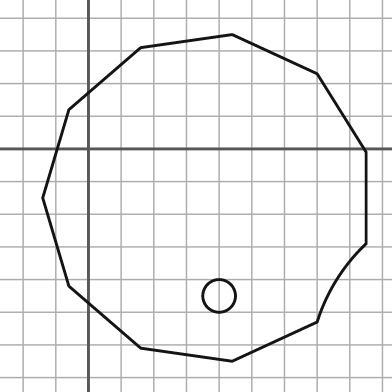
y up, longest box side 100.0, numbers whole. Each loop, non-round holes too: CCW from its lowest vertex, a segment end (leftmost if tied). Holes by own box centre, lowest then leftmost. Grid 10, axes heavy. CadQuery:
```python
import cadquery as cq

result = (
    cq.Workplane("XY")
    .moveTo(44.0, -65.0)
    .lineTo(70.0, -53.0)
    .threePointArc((76.0, -40.0), (85.0, -29.0))
    .lineTo(85.0, -1.0)
    .lineTo(70.0, 23.0)
    .lineTo(44.0, 35.0)
    .lineTo(16.0, 31.0)
    .lineTo(-6.0, 12.0)
    .lineTo(-14.0, -15.0)
    .lineTo(-6.0, -42.0)
    .lineTo(16.0, -61.0)
    .close()
    .moveTo(40.0, -45.0)
    .circle(5.0)
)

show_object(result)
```